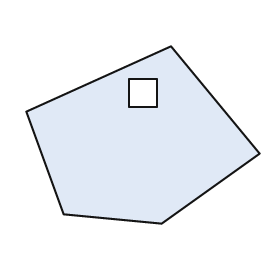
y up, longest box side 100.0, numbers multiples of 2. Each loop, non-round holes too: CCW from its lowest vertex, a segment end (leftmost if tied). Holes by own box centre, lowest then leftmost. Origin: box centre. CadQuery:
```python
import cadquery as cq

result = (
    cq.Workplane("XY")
    .moveTo(8.0, -38.0)
    .lineTo(50.0, -8.0)
    .lineTo(12.0, 38.0)
    .lineTo(-50.0, 10.0)
    .lineTo(-34.0, -34.0)
    .close()
    .moveTo(-6.0, 12.0)
    .lineTo(6.0, 12.0)
    .lineTo(6.0, 24.0)
    .lineTo(-6.0, 24.0)
    .close()
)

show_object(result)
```